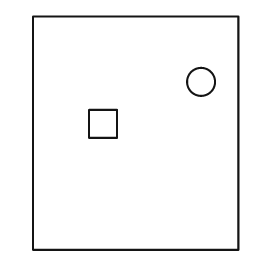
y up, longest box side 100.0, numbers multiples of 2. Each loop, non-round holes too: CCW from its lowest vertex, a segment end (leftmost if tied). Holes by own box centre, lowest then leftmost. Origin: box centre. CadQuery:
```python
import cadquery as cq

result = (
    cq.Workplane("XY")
    .moveTo(-44.0, -50.0)
    .lineTo(44.0, -50.0)
    .lineTo(44.0, 50.0)
    .lineTo(-44.0, 50.0)
    .close()
    .moveTo(-20.0, -2.0)
    .lineTo(-8.0, -2.0)
    .lineTo(-8.0, 10.0)
    .lineTo(-20.0, 10.0)
    .close()
    .moveTo(28.0, 22.0)
    .circle(6.0)
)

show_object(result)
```